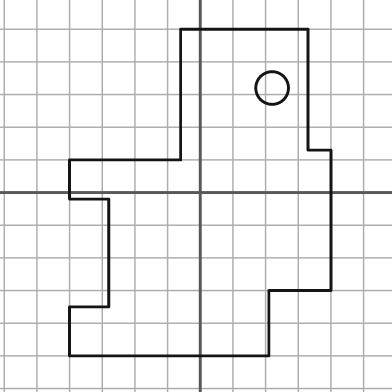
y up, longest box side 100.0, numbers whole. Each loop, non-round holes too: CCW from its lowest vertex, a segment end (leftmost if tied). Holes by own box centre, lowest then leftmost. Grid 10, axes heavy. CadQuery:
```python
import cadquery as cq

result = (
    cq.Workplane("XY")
    .moveTo(-40.0, -50.0)
    .lineTo(21.0, -50.0)
    .lineTo(21.0, -30.0)
    .lineTo(40.0, -30.0)
    .lineTo(40.0, 13.0)
    .lineTo(33.0, 13.0)
    .lineTo(33.0, 50.0)
    .lineTo(-6.0, 50.0)
    .lineTo(-6.0, 10.0)
    .lineTo(-40.0, 10.0)
    .lineTo(-40.0, -2.0)
    .lineTo(-28.0, -2.0)
    .lineTo(-28.0, -35.0)
    .lineTo(-40.0, -35.0)
    .close()
    .moveTo(22.0, 32.0)
    .circle(5.0)
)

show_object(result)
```